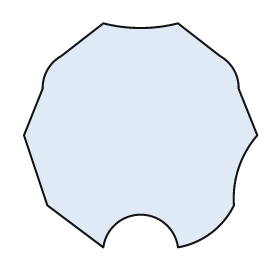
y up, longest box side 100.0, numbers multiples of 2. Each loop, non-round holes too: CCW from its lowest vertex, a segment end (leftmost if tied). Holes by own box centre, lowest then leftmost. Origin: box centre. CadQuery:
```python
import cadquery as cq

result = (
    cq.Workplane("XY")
    .moveTo(-16.0, -48.0)
    .threePointArc((0.0, -34.0), (16.0, -48.0))
    .threePointArc((30.0, -42.0), (40.0, -30.0))
    .threePointArc((42.0, -14.0), (50.0, 0.0))
    .lineTo(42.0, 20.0)
    .threePointArc((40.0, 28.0), (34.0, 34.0))
    .lineTo(16.0, 48.0)
    .threePointArc((0.0, 46.0), (-16.0, 48.0))
    .lineTo(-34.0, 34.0)
    .threePointArc((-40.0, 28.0), (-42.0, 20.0))
    .lineTo(-50.0, 0.0)
    .lineTo(-40.0, -30.0)
    .close()
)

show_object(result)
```